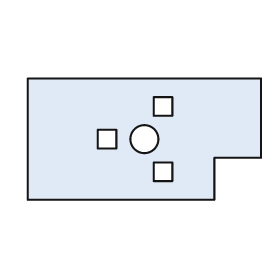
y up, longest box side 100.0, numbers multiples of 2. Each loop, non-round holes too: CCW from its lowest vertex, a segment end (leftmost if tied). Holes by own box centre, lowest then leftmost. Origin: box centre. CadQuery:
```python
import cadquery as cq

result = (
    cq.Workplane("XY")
    .moveTo(-50.0, -26.0)
    .lineTo(30.0, -26.0)
    .lineTo(30.0, -8.0)
    .lineTo(50.0, -8.0)
    .lineTo(50.0, 26.0)
    .lineTo(-50.0, 26.0)
    .close()
    .moveTo(4.0, -18.0)
    .lineTo(12.0, -18.0)
    .lineTo(12.0, -10.0)
    .lineTo(4.0, -10.0)
    .close()
    .moveTo(-20.0, -4.0)
    .lineTo(-12.0, -4.0)
    .lineTo(-12.0, 4.0)
    .lineTo(-20.0, 4.0)
    .close()
    .moveTo(0.0, 0.0)
    .circle(6.0)
    .moveTo(4.0, 10.0)
    .lineTo(12.0, 10.0)
    .lineTo(12.0, 18.0)
    .lineTo(4.0, 18.0)
    .close()
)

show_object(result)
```